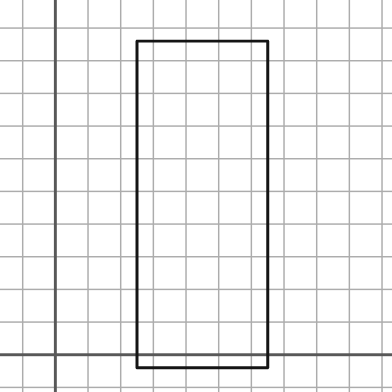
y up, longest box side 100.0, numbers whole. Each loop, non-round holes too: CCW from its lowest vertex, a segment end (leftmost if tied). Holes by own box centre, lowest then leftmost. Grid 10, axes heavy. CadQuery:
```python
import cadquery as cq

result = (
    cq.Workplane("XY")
    .moveTo(25.0, -4.0)
    .lineTo(65.0, -4.0)
    .lineTo(65.0, 96.0)
    .lineTo(25.0, 96.0)
    .close()
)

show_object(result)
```